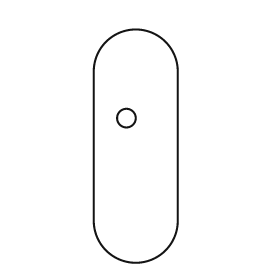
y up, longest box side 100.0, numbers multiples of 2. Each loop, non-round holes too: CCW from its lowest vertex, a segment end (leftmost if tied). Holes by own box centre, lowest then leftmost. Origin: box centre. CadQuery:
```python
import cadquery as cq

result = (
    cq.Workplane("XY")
    .moveTo(-18.0, -32.0)
    .threePointArc((0.0, -50.0), (18.0, -32.0))
    .lineTo(18.0, 32.0)
    .threePointArc((0.0, 50.0), (-18.0, 32.0))
    .close()
    .moveTo(-4.0, 12.0)
    .circle(4.0)
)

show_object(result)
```